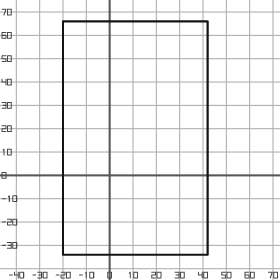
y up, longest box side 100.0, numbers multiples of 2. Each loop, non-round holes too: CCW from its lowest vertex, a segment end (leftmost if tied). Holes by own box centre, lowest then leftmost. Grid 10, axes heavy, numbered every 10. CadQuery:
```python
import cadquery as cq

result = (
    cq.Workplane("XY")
    .moveTo(-20.0, -34.0)
    .lineTo(42.0, -34.0)
    .lineTo(42.0, 66.0)
    .lineTo(-20.0, 66.0)
    .close()
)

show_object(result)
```